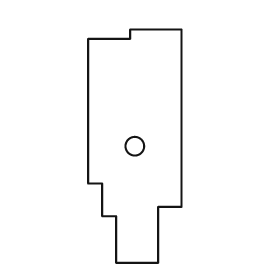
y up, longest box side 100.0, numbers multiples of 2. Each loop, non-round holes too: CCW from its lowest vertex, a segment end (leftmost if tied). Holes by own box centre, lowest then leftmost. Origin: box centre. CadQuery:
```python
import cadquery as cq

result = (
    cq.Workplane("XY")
    .moveTo(-8.0, -50.0)
    .lineTo(10.0, -50.0)
    .lineTo(10.0, -26.0)
    .lineTo(20.0, -26.0)
    .lineTo(20.0, 50.0)
    .lineTo(-2.0, 50.0)
    .lineTo(-2.0, 46.0)
    .lineTo(-20.0, 46.0)
    .lineTo(-20.0, -16.0)
    .lineTo(-14.0, -16.0)
    .lineTo(-14.0, -30.0)
    .lineTo(-8.0, -30.0)
    .close()
    .moveTo(0.0, 0.0)
    .circle(4.0)
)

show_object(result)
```